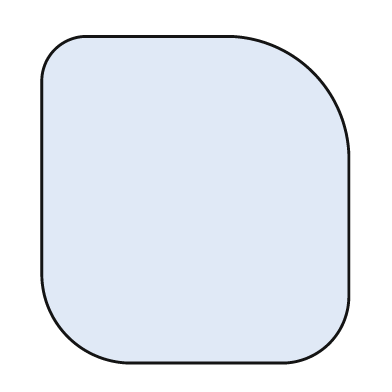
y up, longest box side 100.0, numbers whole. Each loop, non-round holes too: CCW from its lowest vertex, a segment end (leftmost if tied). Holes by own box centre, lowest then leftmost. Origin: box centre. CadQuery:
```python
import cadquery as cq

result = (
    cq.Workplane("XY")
    .moveTo(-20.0, -50.0)
    .lineTo(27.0, -50.0)
    .threePointArc((41.0, -44.0), (47.0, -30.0))
    .lineTo(47.0, 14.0)
    .threePointArc((36.0, 39.0), (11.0, 50.0))
    .lineTo(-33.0, 50.0)
    .threePointArc((-43.0, 46.0), (-47.0, 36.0))
    .lineTo(-47.0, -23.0)
    .threePointArc((-39.0, -42.0), (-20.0, -50.0))
    .close()
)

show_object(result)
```